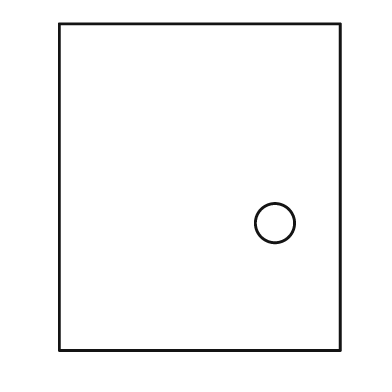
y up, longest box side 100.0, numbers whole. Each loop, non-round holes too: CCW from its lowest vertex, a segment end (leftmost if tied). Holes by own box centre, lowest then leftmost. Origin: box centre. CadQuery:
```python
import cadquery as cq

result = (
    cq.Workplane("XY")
    .moveTo(-43.0, -50.0)
    .lineTo(43.0, -50.0)
    .lineTo(43.0, 50.0)
    .lineTo(-43.0, 50.0)
    .close()
    .moveTo(23.0, -11.0)
    .circle(6.0)
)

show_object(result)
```